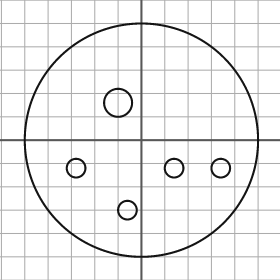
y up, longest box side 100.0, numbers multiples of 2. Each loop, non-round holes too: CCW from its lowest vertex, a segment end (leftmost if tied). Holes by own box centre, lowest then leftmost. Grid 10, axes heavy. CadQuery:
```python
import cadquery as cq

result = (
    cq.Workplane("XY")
    .moveTo(0.0, 0.0)
    .circle(50.0)
    .moveTo(-6.0, -30.0)
    .circle(4.0)
    .moveTo(-28.0, -12.0)
    .circle(4.0)
    .moveTo(14.0, -12.0)
    .circle(4.0)
    .moveTo(34.0, -12.0)
    .circle(4.0)
    .moveTo(-10.0, 16.0)
    .circle(6.0)
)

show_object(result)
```